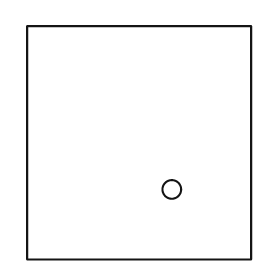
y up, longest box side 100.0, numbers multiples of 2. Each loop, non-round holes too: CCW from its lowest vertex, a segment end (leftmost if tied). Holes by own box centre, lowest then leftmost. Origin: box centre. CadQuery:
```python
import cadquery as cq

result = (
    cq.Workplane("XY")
    .moveTo(-48.0, -50.0)
    .lineTo(48.0, -50.0)
    .lineTo(48.0, 50.0)
    .lineTo(-48.0, 50.0)
    .close()
    .moveTo(14.0, -20.0)
    .circle(4.0)
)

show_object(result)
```